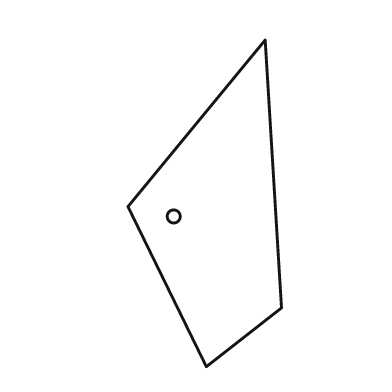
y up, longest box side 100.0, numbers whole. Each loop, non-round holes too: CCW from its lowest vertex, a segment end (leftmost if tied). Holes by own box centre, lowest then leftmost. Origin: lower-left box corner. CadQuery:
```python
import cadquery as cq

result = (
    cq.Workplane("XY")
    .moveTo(24.0, 0.0)
    .lineTo(47.0, 18.0)
    .lineTo(42.0, 100.0)
    .lineTo(0.0, 49.0)
    .close()
    .moveTo(14.0, 46.0)
    .circle(2.0)
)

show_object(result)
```